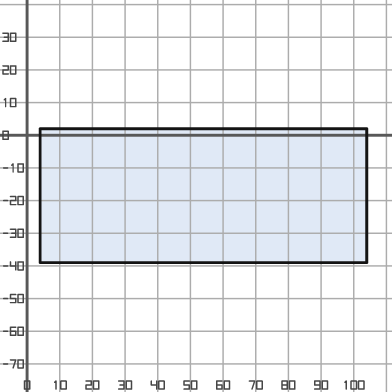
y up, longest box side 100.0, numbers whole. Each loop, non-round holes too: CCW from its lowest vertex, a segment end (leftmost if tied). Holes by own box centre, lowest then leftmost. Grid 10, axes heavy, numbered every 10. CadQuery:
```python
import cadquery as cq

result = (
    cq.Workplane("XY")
    .moveTo(4.0, -39.0)
    .lineTo(104.0, -39.0)
    .lineTo(104.0, 2.0)
    .lineTo(4.0, 2.0)
    .close()
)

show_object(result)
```